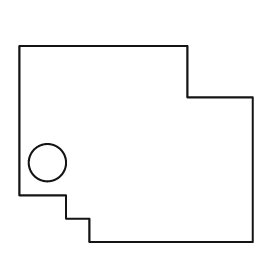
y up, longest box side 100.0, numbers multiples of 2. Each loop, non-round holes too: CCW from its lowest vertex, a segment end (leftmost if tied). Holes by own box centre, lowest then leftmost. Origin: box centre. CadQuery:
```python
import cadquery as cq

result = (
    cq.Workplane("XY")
    .moveTo(-20.0, -42.0)
    .lineTo(50.0, -42.0)
    .lineTo(50.0, 20.0)
    .lineTo(22.0, 20.0)
    .lineTo(22.0, 42.0)
    .lineTo(-50.0, 42.0)
    .lineTo(-50.0, -22.0)
    .lineTo(-30.0, -22.0)
    .lineTo(-30.0, -32.0)
    .lineTo(-20.0, -32.0)
    .close()
    .moveTo(-38.0, -8.0)
    .circle(8.0)
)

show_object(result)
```